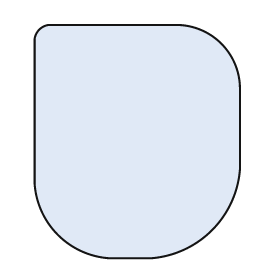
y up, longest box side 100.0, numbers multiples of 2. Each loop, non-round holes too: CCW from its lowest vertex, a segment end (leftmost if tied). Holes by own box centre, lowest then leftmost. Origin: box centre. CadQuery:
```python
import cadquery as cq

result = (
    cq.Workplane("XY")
    .moveTo(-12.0, -50.0)
    .lineTo(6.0, -50.0)
    .threePointArc((32.0, -38.0), (44.0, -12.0))
    .lineTo(44.0, 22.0)
    .threePointArc((36.0, 42.0), (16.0, 50.0))
    .lineTo(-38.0, 50.0)
    .threePointArc((-42.0, 48.0), (-44.0, 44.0))
    .lineTo(-44.0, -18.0)
    .threePointArc((-34.0, -40.0), (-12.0, -50.0))
    .close()
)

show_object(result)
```